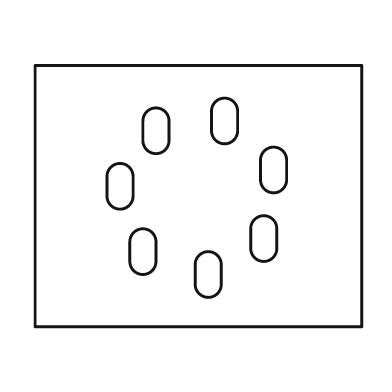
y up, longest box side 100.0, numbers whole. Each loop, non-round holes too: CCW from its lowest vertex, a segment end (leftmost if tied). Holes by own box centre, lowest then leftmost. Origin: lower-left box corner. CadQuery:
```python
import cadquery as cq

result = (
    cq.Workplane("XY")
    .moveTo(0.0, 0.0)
    .lineTo(100.0, 0.0)
    .lineTo(100.0, 80.0)
    .lineTo(0.0, 80.0)
    .close()
    .moveTo(49.0, 13.0)
    .threePointArc((53.0, 9.0), (57.0, 13.0))
    .lineTo(57.0, 19.0)
    .threePointArc((53.0, 23.0), (49.0, 19.0))
    .close()
    .moveTo(29.0, 20.0)
    .threePointArc((33.0, 16.0), (37.0, 20.0))
    .lineTo(37.0, 26.0)
    .threePointArc((33.0, 30.0), (29.0, 26.0))
    .close()
    .moveTo(66.0, 24.0)
    .threePointArc((70.0, 20.0), (74.0, 24.0))
    .lineTo(74.0, 30.0)
    .threePointArc((70.0, 34.0), (66.0, 30.0))
    .close()
    .moveTo(22.0, 40.0)
    .threePointArc((26.0, 36.0), (30.0, 40.0))
    .lineTo(30.0, 46.0)
    .threePointArc((26.0, 50.0), (22.0, 46.0))
    .close()
    .moveTo(69.0, 45.0)
    .threePointArc((73.0, 41.0), (77.0, 45.0))
    .lineTo(77.0, 51.0)
    .threePointArc((73.0, 55.0), (69.0, 51.0))
    .close()
    .moveTo(33.0, 57.0)
    .threePointArc((37.0, 53.0), (41.0, 57.0))
    .lineTo(41.0, 63.0)
    .threePointArc((37.0, 67.0), (33.0, 63.0))
    .close()
    .moveTo(54.0, 60.0)
    .threePointArc((58.0, 56.0), (62.0, 60.0))
    .lineTo(62.0, 66.0)
    .threePointArc((58.0, 70.0), (54.0, 66.0))
    .close()
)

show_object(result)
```